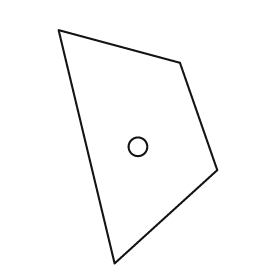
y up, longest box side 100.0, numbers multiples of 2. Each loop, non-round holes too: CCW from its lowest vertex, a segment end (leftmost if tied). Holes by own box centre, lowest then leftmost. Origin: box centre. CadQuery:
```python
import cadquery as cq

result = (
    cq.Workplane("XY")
    .moveTo(-10.0, -50.0)
    .lineTo(34.0, -10.0)
    .lineTo(18.0, 36.0)
    .lineTo(-34.0, 50.0)
    .close()
    .moveTo(0.0, 0.0)
    .circle(4.0)
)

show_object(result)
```